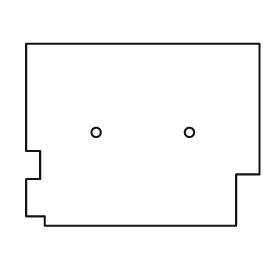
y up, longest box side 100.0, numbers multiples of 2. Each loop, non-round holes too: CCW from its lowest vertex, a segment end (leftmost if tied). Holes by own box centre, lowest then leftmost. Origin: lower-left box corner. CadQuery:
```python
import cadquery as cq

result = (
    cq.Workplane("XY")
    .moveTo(8.0, 0.0)
    .lineTo(90.0, 0.0)
    .lineTo(90.0, 22.0)
    .lineTo(100.0, 22.0)
    .lineTo(100.0, 78.0)
    .lineTo(0.0, 78.0)
    .lineTo(0.0, 32.0)
    .lineTo(6.0, 32.0)
    .lineTo(6.0, 20.0)
    .lineTo(0.0, 20.0)
    .lineTo(0.0, 4.0)
    .lineTo(8.0, 4.0)
    .close()
    .moveTo(30.0, 40.0)
    .circle(2.0)
    .moveTo(70.0, 40.0)
    .circle(2.0)
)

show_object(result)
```